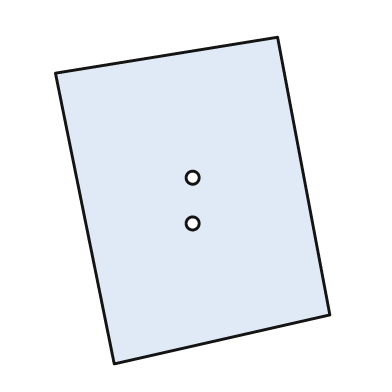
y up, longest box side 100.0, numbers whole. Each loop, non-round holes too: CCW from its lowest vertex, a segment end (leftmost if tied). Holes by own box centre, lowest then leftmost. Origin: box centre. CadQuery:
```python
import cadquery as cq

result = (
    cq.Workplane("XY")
    .moveTo(-24.0, -50.0)
    .lineTo(42.0, -35.0)
    .lineTo(26.0, 50.0)
    .lineTo(-42.0, 39.0)
    .close()
    .moveTo(0.0, -7.0)
    .circle(2.0)
    .moveTo(0.0, 7.0)
    .circle(2.0)
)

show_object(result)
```